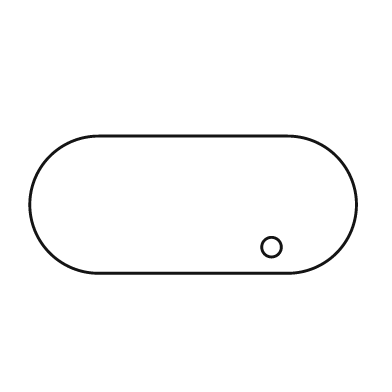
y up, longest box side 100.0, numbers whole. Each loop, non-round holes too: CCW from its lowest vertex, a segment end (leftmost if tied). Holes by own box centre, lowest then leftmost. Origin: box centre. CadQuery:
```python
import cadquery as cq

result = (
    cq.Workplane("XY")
    .moveTo(-29.0, -21.0)
    .lineTo(29.0, -21.0)
    .threePointArc((50.0, 0.0), (29.0, 21.0))
    .lineTo(-29.0, 21.0)
    .threePointArc((-50.0, 0.0), (-29.0, -21.0))
    .close()
    .moveTo(24.0, -13.0)
    .circle(3.0)
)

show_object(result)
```